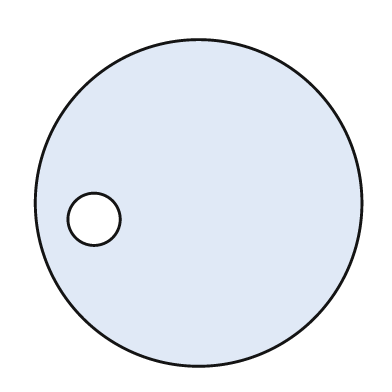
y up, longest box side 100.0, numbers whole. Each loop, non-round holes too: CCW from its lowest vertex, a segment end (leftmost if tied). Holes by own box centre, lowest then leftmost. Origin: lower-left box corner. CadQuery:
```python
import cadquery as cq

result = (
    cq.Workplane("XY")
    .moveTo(50.0, 50.0)
    .circle(50.0)
    .moveTo(18.0, 45.0)
    .circle(8.0)
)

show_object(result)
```